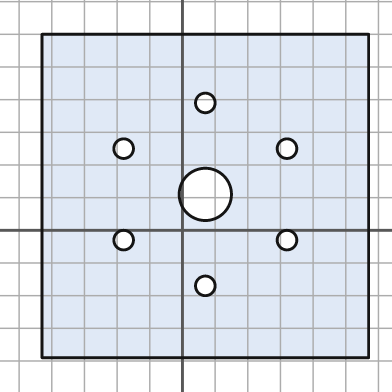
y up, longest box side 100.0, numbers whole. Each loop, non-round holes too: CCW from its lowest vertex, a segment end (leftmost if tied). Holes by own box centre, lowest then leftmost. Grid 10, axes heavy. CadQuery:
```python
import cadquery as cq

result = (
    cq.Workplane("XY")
    .moveTo(-43.0, -39.0)
    .lineTo(57.0, -39.0)
    .lineTo(57.0, 60.0)
    .lineTo(-43.0, 60.0)
    .close()
    .moveTo(7.0, -17.0)
    .circle(3.0)
    .moveTo(-18.0, -3.0)
    .circle(3.0)
    .moveTo(32.0, -3.0)
    .circle(3.0)
    .moveTo(7.0, 11.0)
    .circle(8.0)
    .moveTo(-18.0, 25.0)
    .circle(3.0)
    .moveTo(32.0, 25.0)
    .circle(3.0)
    .moveTo(7.0, 39.0)
    .circle(3.0)
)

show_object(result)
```